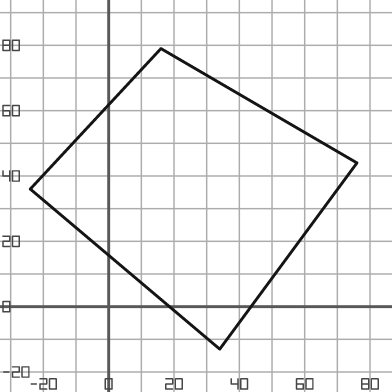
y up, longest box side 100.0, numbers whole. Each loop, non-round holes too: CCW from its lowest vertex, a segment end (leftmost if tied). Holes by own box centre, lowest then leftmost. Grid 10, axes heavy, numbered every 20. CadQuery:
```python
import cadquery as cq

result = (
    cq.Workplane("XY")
    .moveTo(34.0, -13.0)
    .lineTo(76.0, 44.0)
    .lineTo(16.0, 79.0)
    .lineTo(-24.0, 36.0)
    .close()
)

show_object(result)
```